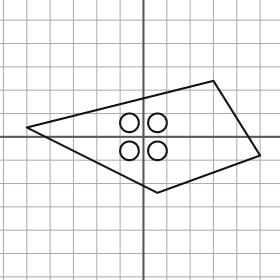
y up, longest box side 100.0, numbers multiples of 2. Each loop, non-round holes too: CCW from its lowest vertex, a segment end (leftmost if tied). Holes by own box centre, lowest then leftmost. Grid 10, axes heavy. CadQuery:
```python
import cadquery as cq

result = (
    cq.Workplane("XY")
    .moveTo(6.0, -24.0)
    .lineTo(50.0, -8.0)
    .lineTo(30.0, 24.0)
    .lineTo(-50.0, 4.0)
    .close()
    .moveTo(-6.0, -6.0)
    .circle(4.0)
    .moveTo(6.0, -6.0)
    .circle(4.0)
    .moveTo(-6.0, 6.0)
    .circle(4.0)
    .moveTo(6.0, 6.0)
    .circle(4.0)
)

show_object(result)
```